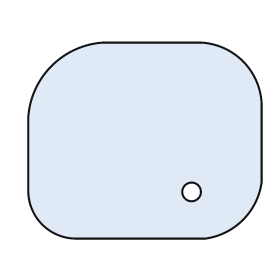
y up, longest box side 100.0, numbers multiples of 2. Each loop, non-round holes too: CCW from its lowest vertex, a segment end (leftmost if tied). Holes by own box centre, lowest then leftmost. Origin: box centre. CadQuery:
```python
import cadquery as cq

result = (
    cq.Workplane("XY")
    .moveTo(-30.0, -42.0)
    .lineTo(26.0, -42.0)
    .threePointArc((42.0, -34.0), (50.0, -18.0))
    .lineTo(50.0, 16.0)
    .threePointArc((42.0, 34.0), (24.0, 42.0))
    .lineTo(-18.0, 42.0)
    .threePointArc((-40.0, 32.0), (-50.0, 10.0))
    .lineTo(-50.0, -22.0)
    .threePointArc((-44.0, -36.0), (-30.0, -42.0))
    .close()
    .moveTo(20.0, -22.0)
    .circle(4.0)
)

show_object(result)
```